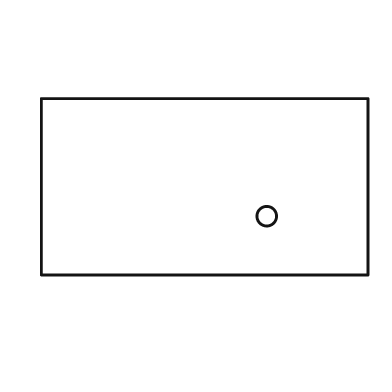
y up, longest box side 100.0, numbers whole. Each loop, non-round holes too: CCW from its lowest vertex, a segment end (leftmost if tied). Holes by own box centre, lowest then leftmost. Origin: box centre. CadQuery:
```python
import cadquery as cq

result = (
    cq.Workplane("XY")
    .moveTo(-50.0, -27.0)
    .lineTo(50.0, -27.0)
    .lineTo(50.0, 27.0)
    .lineTo(-50.0, 27.0)
    .close()
    .moveTo(19.0, -9.0)
    .circle(3.0)
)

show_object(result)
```